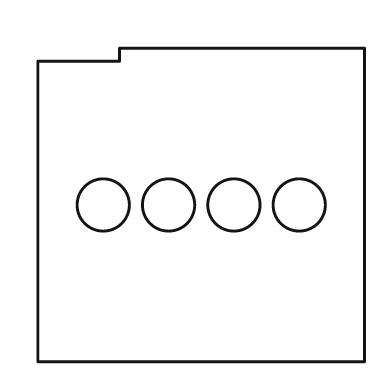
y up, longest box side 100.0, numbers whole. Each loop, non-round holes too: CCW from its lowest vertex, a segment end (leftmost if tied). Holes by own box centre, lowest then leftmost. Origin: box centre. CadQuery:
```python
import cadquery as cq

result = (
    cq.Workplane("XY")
    .moveTo(-50.0, -48.0)
    .lineTo(50.0, -48.0)
    .lineTo(50.0, 48.0)
    .lineTo(-25.0, 48.0)
    .lineTo(-25.0, 44.0)
    .lineTo(-50.0, 44.0)
    .close()
    .moveTo(-30.0, 0.0)
    .circle(8.0)
    .moveTo(-10.0, 0.0)
    .circle(8.0)
    .moveTo(10.0, 0.0)
    .circle(8.0)
    .moveTo(30.0, 0.0)
    .circle(8.0)
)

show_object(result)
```